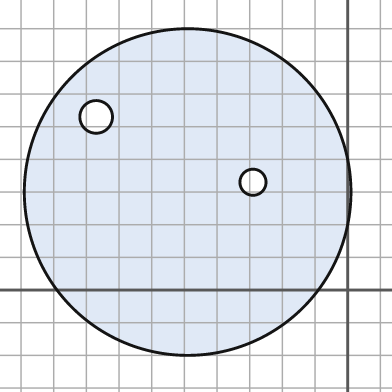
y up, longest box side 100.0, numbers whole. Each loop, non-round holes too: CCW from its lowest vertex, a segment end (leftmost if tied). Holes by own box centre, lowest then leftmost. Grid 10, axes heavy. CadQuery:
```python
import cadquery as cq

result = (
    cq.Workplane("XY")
    .moveTo(-49.0, 30.0)
    .circle(50.0)
    .moveTo(-29.0, 33.0)
    .circle(4.0)
    .moveTo(-77.0, 53.0)
    .circle(5.0)
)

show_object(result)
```